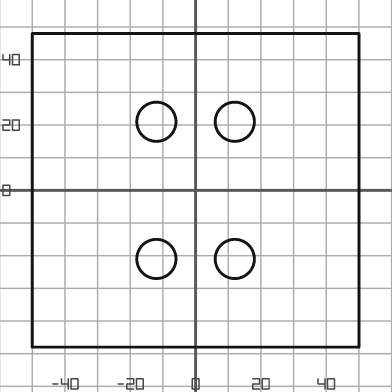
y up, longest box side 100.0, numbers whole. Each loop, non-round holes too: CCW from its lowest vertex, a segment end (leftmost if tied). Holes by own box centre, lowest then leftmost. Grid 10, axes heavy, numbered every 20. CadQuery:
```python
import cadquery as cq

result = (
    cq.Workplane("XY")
    .moveTo(-50.0, -48.0)
    .lineTo(50.0, -48.0)
    .lineTo(50.0, 48.0)
    .lineTo(-50.0, 48.0)
    .close()
    .moveTo(-12.0, -21.0)
    .circle(6.0)
    .moveTo(12.0, -21.0)
    .circle(6.0)
    .moveTo(-12.0, 21.0)
    .circle(6.0)
    .moveTo(12.0, 21.0)
    .circle(6.0)
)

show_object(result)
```